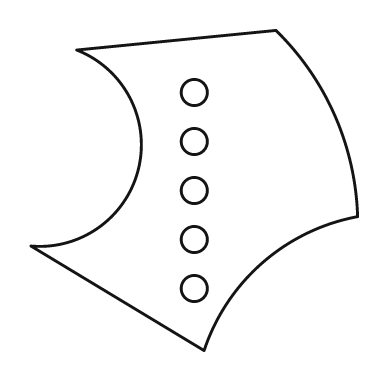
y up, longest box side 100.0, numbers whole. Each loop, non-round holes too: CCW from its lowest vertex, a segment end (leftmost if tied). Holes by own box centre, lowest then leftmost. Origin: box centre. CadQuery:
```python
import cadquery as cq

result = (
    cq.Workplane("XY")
    .moveTo(3.0, -49.0)
    .threePointArc((21.0, -22.0), (50.0, -8.0))
    .threePointArc((43.0, 23.0), (25.0, 49.0))
    .lineTo(-36.0, 43.0)
    .threePointArc((-17.0, 7.0), (-50.0, -17.0))
    .close()
    .moveTo(0.0, -30.0)
    .circle(4.0)
    .moveTo(0.0, -15.0)
    .circle(4.0)
    .moveTo(0.0, 0.0)
    .circle(4.0)
    .moveTo(0.0, 15.0)
    .circle(4.0)
    .moveTo(0.0, 30.0)
    .circle(4.0)
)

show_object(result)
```